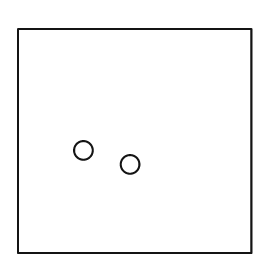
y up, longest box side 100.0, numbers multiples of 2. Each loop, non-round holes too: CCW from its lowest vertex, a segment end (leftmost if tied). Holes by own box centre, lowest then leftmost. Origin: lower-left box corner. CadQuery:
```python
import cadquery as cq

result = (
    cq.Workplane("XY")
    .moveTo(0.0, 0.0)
    .lineTo(100.0, 0.0)
    .lineTo(100.0, 96.0)
    .lineTo(0.0, 96.0)
    .close()
    .moveTo(48.0, 38.0)
    .circle(4.0)
    .moveTo(28.0, 44.0)
    .circle(4.0)
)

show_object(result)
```